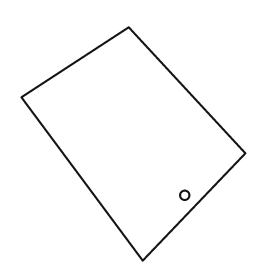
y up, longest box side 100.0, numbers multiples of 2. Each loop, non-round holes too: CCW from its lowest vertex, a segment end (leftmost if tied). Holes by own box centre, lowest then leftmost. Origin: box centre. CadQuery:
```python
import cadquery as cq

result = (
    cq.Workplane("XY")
    .moveTo(4.0, -50.0)
    .lineTo(48.0, -4.0)
    .lineTo(-2.0, 50.0)
    .lineTo(-48.0, 20.0)
    .close()
    .moveTo(22.0, -22.0)
    .circle(2.0)
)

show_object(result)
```